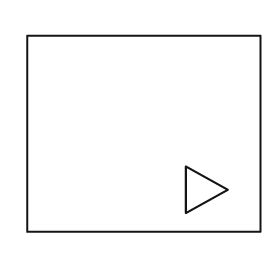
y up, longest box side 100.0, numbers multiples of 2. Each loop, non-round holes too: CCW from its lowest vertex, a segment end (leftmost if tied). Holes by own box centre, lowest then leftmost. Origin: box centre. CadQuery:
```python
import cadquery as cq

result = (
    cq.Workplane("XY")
    .moveTo(-50.0, -42.0)
    .lineTo(50.0, -42.0)
    .lineTo(50.0, 42.0)
    .lineTo(-50.0, 42.0)
    .close()
    .moveTo(18.0, -34.0)
    .lineTo(36.0, -24.0)
    .lineTo(18.0, -14.0)
    .close()
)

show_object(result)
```